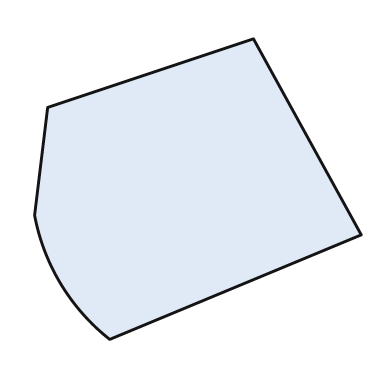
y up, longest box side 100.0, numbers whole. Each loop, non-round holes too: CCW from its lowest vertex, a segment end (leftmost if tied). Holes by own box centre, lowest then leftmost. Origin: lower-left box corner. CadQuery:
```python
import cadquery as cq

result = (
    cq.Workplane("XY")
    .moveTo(23.0, 0.0)
    .lineTo(100.0, 32.0)
    .lineTo(67.0, 92.0)
    .lineTo(4.0, 71.0)
    .lineTo(0.0, 38.0)
    .threePointArc((8.0, 17.0), (23.0, 0.0))
    .close()
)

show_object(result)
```